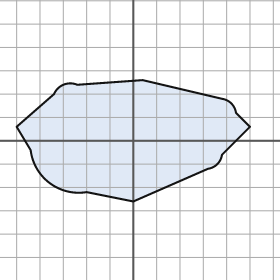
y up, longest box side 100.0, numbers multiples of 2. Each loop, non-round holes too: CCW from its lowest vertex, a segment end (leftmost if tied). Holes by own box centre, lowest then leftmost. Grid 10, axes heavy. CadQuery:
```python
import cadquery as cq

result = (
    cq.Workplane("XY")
    .moveTo(0.0, -26.0)
    .lineTo(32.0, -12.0)
    .threePointArc((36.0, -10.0), (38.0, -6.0))
    .lineTo(50.0, 6.0)
    .lineTo(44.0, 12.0)
    .threePointArc((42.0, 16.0), (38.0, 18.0))
    .lineTo(4.0, 26.0)
    .lineTo(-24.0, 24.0)
    .threePointArc((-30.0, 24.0), (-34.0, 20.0))
    .lineTo(-50.0, 6.0)
    .lineTo(-44.0, -4.0)
    .threePointArc((-36.0, -18.0), (-20.0, -22.0))
    .close()
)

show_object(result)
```